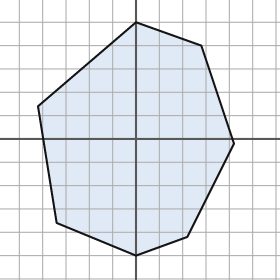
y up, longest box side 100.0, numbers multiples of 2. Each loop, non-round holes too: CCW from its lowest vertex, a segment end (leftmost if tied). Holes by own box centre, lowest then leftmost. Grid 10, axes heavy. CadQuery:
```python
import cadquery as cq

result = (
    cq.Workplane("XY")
    .moveTo(0.0, -50.0)
    .lineTo(22.0, -42.0)
    .lineTo(42.0, -2.0)
    .lineTo(28.0, 40.0)
    .lineTo(0.0, 50.0)
    .lineTo(-42.0, 14.0)
    .lineTo(-34.0, -36.0)
    .close()
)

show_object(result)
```